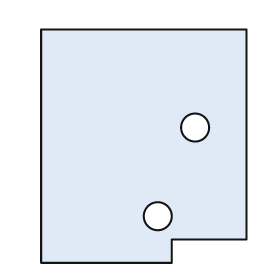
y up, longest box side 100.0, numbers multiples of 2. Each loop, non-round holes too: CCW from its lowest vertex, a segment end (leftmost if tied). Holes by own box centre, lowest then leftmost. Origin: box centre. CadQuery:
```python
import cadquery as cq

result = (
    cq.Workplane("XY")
    .moveTo(-44.0, -50.0)
    .lineTo(12.0, -50.0)
    .lineTo(12.0, -40.0)
    .lineTo(44.0, -40.0)
    .lineTo(44.0, 50.0)
    .lineTo(-44.0, 50.0)
    .close()
    .moveTo(6.0, -30.0)
    .circle(6.0)
    .moveTo(22.0, 8.0)
    .circle(6.0)
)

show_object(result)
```